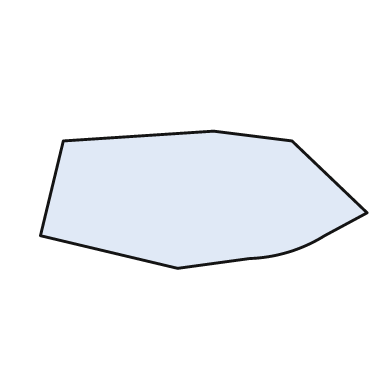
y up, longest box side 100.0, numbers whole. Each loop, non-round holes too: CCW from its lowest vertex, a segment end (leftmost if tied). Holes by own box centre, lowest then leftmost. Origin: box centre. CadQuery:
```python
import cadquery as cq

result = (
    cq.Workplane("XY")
    .moveTo(-8.0, -21.0)
    .lineTo(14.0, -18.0)
    .threePointArc((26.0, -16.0), (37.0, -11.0))
    .lineTo(50.0, -4.0)
    .lineTo(27.0, 18.0)
    .lineTo(3.0, 21.0)
    .lineTo(-43.0, 18.0)
    .lineTo(-50.0, -11.0)
    .close()
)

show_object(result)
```